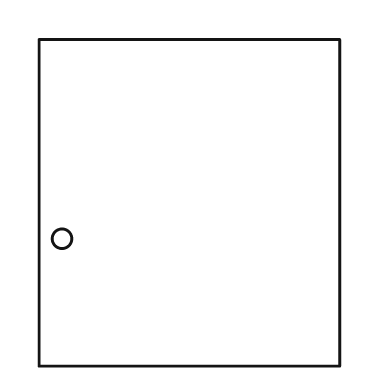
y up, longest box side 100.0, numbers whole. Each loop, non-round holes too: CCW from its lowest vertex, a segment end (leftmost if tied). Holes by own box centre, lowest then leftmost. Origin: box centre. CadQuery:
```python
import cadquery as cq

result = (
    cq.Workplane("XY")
    .moveTo(-46.0, -50.0)
    .lineTo(46.0, -50.0)
    .lineTo(46.0, 50.0)
    .lineTo(-46.0, 50.0)
    .close()
    .moveTo(-39.0, -11.0)
    .circle(3.0)
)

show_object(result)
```